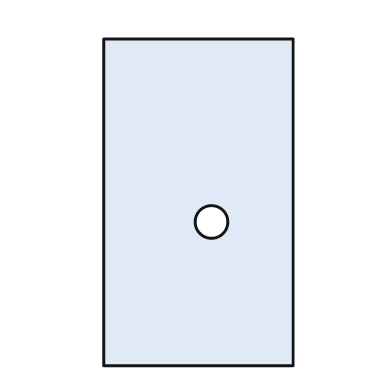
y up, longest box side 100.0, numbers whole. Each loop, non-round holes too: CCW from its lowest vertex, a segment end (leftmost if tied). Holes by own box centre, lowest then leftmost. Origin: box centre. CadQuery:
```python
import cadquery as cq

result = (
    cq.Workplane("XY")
    .moveTo(-29.0, -50.0)
    .lineTo(29.0, -50.0)
    .lineTo(29.0, 50.0)
    .lineTo(-29.0, 50.0)
    .close()
    .moveTo(4.0, -6.0)
    .circle(5.0)
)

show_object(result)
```